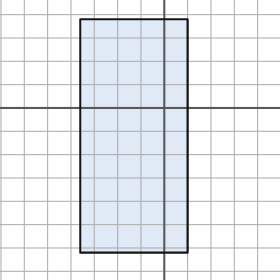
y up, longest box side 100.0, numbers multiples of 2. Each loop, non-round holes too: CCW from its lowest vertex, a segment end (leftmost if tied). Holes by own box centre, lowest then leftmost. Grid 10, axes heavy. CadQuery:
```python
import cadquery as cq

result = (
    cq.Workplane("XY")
    .moveTo(-36.0, -62.0)
    .lineTo(10.0, -62.0)
    .lineTo(10.0, 38.0)
    .lineTo(-36.0, 38.0)
    .close()
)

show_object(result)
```